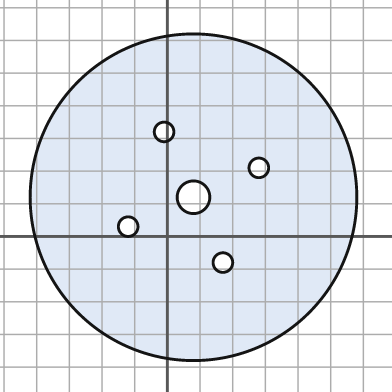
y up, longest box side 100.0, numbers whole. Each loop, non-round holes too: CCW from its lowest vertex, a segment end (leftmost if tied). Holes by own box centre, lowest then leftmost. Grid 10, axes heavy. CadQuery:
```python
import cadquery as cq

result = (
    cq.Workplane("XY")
    .moveTo(8.0, 12.0)
    .circle(50.0)
    .moveTo(17.0, -8.0)
    .circle(3.0)
    .moveTo(-12.0, 3.0)
    .circle(3.0)
    .moveTo(8.0, 12.0)
    .circle(5.0)
    .moveTo(28.0, 21.0)
    .circle(3.0)
    .moveTo(-1.0, 32.0)
    .circle(3.0)
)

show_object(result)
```